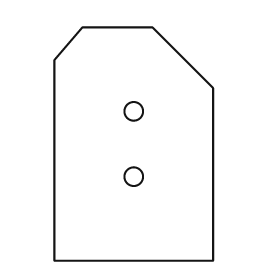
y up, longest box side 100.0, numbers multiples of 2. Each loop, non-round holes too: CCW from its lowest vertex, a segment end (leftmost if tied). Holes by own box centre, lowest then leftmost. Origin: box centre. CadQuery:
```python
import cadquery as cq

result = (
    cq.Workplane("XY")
    .moveTo(-34.0, -50.0)
    .lineTo(34.0, -50.0)
    .lineTo(34.0, 24.0)
    .lineTo(8.0, 50.0)
    .lineTo(-22.0, 50.0)
    .lineTo(-34.0, 36.0)
    .close()
    .moveTo(0.0, -14.0)
    .circle(4.0)
    .moveTo(0.0, 14.0)
    .circle(4.0)
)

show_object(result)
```